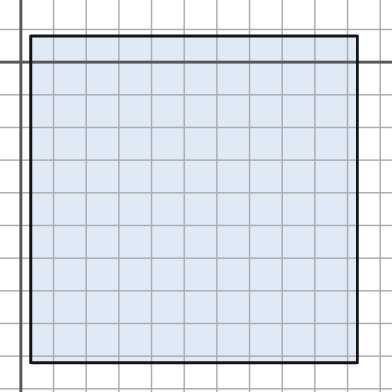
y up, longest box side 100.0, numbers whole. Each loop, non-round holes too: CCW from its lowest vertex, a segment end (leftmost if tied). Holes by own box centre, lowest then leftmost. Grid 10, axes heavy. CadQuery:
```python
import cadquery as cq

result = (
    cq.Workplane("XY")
    .moveTo(3.0, -92.0)
    .lineTo(103.0, -92.0)
    .lineTo(103.0, 8.0)
    .lineTo(3.0, 8.0)
    .close()
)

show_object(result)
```